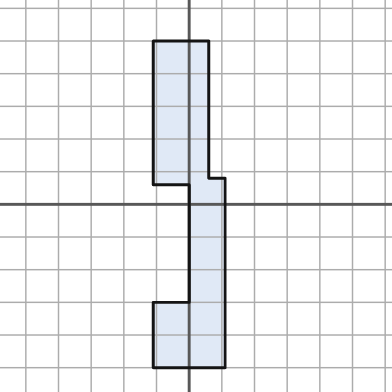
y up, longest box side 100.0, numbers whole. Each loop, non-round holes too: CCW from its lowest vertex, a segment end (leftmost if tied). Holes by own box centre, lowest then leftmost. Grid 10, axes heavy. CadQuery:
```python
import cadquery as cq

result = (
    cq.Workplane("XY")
    .moveTo(-11.0, -50.0)
    .lineTo(11.0, -50.0)
    .lineTo(11.0, 8.0)
    .lineTo(6.0, 8.0)
    .lineTo(6.0, 50.0)
    .lineTo(-11.0, 50.0)
    .lineTo(-11.0, 6.0)
    .lineTo(0.0, 6.0)
    .lineTo(0.0, -30.0)
    .lineTo(-11.0, -30.0)
    .close()
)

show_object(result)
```